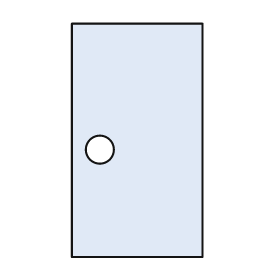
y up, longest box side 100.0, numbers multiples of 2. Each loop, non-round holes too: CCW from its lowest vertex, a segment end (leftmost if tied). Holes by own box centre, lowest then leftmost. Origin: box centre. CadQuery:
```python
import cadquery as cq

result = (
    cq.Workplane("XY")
    .moveTo(-28.0, -50.0)
    .lineTo(28.0, -50.0)
    .lineTo(28.0, 50.0)
    .lineTo(-28.0, 50.0)
    .close()
    .moveTo(-16.0, -4.0)
    .circle(6.0)
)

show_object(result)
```